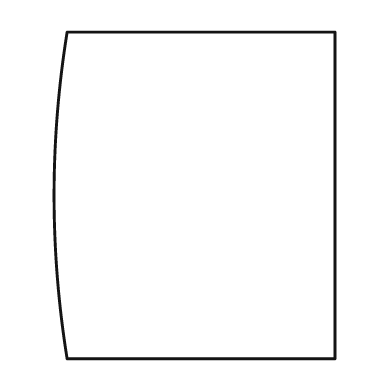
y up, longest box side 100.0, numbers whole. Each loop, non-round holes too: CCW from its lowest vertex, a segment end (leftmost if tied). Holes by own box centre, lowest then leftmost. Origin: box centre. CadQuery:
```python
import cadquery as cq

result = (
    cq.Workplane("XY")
    .moveTo(-39.0, -50.0)
    .lineTo(43.0, -50.0)
    .lineTo(43.0, 50.0)
    .lineTo(-39.0, 50.0)
    .threePointArc((-43.0, 0.0), (-39.0, -50.0))
    .close()
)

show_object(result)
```